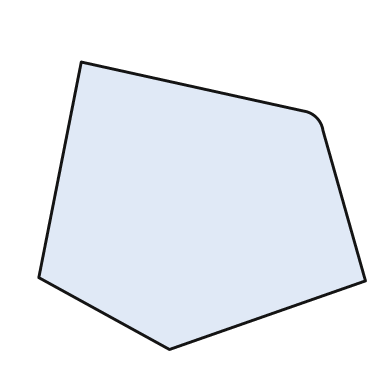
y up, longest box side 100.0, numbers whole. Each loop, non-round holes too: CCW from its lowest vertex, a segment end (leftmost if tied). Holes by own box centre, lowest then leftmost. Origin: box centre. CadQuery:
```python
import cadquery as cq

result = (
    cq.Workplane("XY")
    .moveTo(-10.0, -44.0)
    .lineTo(50.0, -23.0)
    .lineTo(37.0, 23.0)
    .threePointArc((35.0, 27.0), (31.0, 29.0))
    .lineTo(-37.0, 44.0)
    .lineTo(-50.0, -22.0)
    .close()
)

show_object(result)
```